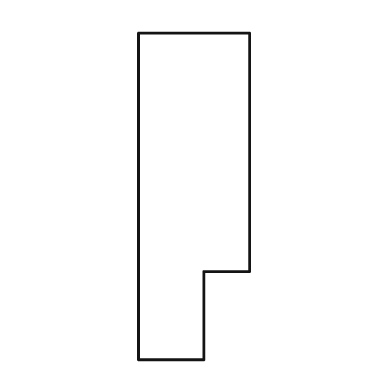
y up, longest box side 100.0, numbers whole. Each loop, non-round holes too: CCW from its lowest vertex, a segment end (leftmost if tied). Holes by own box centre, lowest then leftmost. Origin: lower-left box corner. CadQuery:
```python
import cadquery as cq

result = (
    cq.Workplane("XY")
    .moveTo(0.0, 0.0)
    .lineTo(20.0, 0.0)
    .lineTo(20.0, 27.0)
    .lineTo(34.0, 27.0)
    .lineTo(34.0, 100.0)
    .lineTo(0.0, 100.0)
    .close()
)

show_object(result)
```